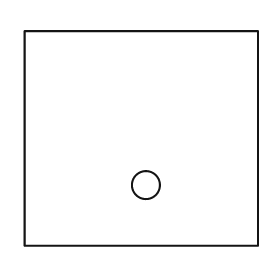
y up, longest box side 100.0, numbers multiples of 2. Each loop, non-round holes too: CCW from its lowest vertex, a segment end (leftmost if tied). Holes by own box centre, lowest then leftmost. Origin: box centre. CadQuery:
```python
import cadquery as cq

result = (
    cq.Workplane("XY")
    .moveTo(-50.0, -46.0)
    .lineTo(50.0, -46.0)
    .lineTo(50.0, 46.0)
    .lineTo(-50.0, 46.0)
    .close()
    .moveTo(2.0, -20.0)
    .circle(6.0)
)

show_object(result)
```